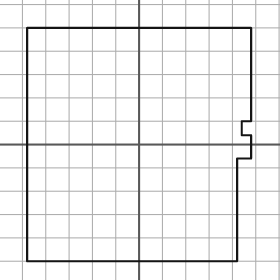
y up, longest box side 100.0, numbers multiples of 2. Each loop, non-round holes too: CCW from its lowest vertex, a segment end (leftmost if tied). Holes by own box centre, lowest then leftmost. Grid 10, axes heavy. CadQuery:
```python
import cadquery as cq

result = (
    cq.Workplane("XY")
    .moveTo(-48.0, -50.0)
    .lineTo(42.0, -50.0)
    .lineTo(42.0, -6.0)
    .lineTo(48.0, -6.0)
    .lineTo(48.0, 4.0)
    .lineTo(44.0, 4.0)
    .lineTo(44.0, 10.0)
    .lineTo(48.0, 10.0)
    .lineTo(48.0, 50.0)
    .lineTo(-48.0, 50.0)
    .close()
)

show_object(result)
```